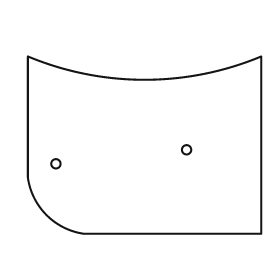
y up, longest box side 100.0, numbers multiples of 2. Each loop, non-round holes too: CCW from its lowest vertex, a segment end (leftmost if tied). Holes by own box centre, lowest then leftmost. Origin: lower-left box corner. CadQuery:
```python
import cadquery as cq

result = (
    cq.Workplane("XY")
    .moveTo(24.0, 0.0)
    .lineTo(100.0, 0.0)
    .lineTo(100.0, 76.0)
    .threePointArc((50.0, 66.0), (0.0, 76.0))
    .lineTo(0.0, 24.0)
    .threePointArc((8.0, 8.0), (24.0, 0.0))
    .close()
    .moveTo(12.0, 30.0)
    .circle(2.0)
    .moveTo(68.0, 36.0)
    .circle(2.0)
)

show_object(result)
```